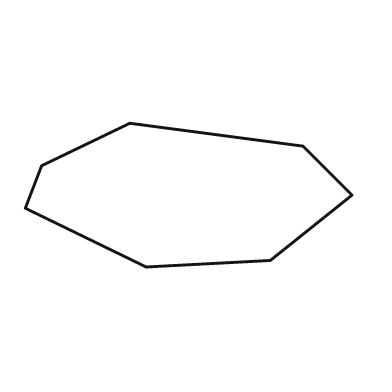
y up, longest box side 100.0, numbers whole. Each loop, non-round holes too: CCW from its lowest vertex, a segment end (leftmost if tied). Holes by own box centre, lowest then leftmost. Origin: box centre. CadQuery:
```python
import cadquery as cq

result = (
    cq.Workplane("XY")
    .moveTo(-13.0, -22.0)
    .lineTo(25.0, -20.0)
    .lineTo(50.0, 0.0)
    .lineTo(35.0, 15.0)
    .lineTo(-18.0, 22.0)
    .lineTo(-45.0, 9.0)
    .lineTo(-50.0, -4.0)
    .close()
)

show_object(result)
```